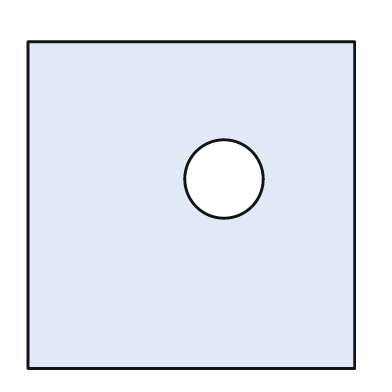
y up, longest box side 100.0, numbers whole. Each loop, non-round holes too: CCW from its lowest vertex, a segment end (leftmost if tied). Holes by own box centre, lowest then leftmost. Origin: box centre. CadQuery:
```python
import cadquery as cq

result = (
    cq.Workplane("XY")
    .moveTo(-50.0, -50.0)
    .lineTo(50.0, -50.0)
    .lineTo(50.0, 50.0)
    .lineTo(-50.0, 50.0)
    .close()
    .moveTo(10.0, 8.0)
    .circle(12.0)
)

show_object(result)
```